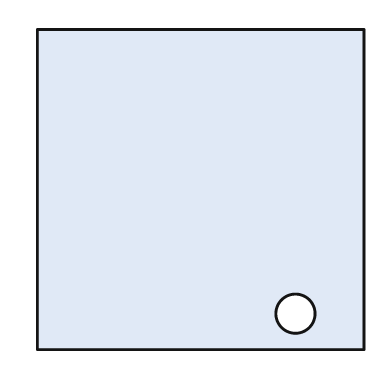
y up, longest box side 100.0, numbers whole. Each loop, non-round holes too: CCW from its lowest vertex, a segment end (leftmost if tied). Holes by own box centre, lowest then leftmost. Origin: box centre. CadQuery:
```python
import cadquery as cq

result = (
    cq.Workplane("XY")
    .moveTo(-50.0, -49.0)
    .lineTo(50.0, -49.0)
    .lineTo(50.0, 49.0)
    .lineTo(-50.0, 49.0)
    .close()
    .moveTo(29.0, -38.0)
    .circle(6.0)
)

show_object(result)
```